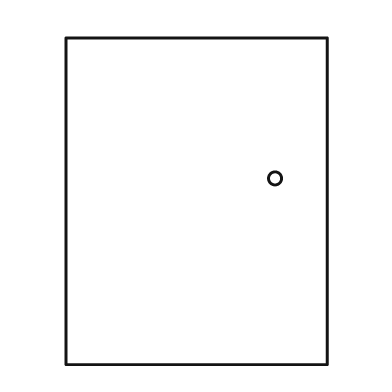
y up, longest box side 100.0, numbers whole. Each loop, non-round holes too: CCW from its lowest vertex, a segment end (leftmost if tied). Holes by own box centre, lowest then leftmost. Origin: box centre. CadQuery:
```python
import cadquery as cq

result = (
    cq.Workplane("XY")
    .moveTo(-40.0, -50.0)
    .lineTo(40.0, -50.0)
    .lineTo(40.0, 50.0)
    .lineTo(-40.0, 50.0)
    .close()
    .moveTo(24.0, 7.0)
    .circle(2.0)
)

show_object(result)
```